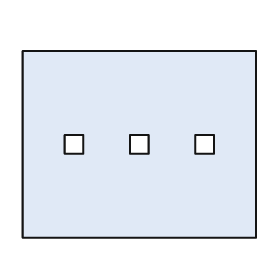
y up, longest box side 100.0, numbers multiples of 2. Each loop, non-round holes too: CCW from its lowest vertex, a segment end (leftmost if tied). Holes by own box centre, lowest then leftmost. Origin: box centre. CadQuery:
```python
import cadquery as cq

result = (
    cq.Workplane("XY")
    .moveTo(-50.0, -40.0)
    .lineTo(50.0, -40.0)
    .lineTo(50.0, 40.0)
    .lineTo(-50.0, 40.0)
    .close()
    .moveTo(-32.0, -4.0)
    .lineTo(-24.0, -4.0)
    .lineTo(-24.0, 4.0)
    .lineTo(-32.0, 4.0)
    .close()
    .moveTo(-4.0, -4.0)
    .lineTo(4.0, -4.0)
    .lineTo(4.0, 4.0)
    .lineTo(-4.0, 4.0)
    .close()
    .moveTo(24.0, -4.0)
    .lineTo(32.0, -4.0)
    .lineTo(32.0, 4.0)
    .lineTo(24.0, 4.0)
    .close()
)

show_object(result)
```